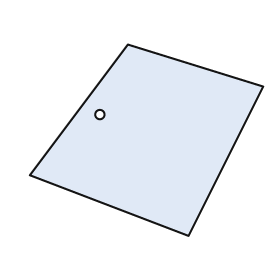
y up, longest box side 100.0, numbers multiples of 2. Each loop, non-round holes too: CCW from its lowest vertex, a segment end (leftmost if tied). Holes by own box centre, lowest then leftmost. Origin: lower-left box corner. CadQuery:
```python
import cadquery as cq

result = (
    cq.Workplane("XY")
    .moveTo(68.0, 0.0)
    .lineTo(100.0, 64.0)
    .lineTo(42.0, 82.0)
    .lineTo(0.0, 26.0)
    .close()
    .moveTo(30.0, 52.0)
    .circle(2.0)
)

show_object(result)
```